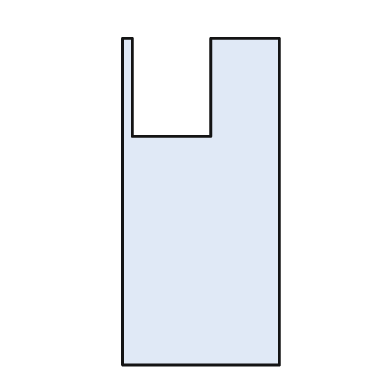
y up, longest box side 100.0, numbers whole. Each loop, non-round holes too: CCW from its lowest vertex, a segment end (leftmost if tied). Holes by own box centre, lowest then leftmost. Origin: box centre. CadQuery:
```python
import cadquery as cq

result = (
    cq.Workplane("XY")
    .moveTo(-24.0, -50.0)
    .lineTo(24.0, -50.0)
    .lineTo(24.0, 50.0)
    .lineTo(3.0, 50.0)
    .lineTo(3.0, 20.0)
    .lineTo(-21.0, 20.0)
    .lineTo(-21.0, 50.0)
    .lineTo(-24.0, 50.0)
    .close()
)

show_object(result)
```